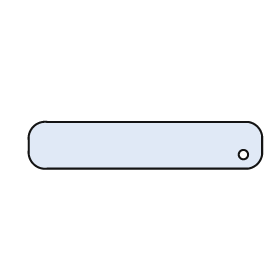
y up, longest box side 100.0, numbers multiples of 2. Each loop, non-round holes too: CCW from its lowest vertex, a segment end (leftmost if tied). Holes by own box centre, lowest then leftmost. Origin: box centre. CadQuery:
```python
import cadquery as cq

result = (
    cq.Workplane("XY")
    .moveTo(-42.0, -10.0)
    .lineTo(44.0, -10.0)
    .threePointArc((48.0, -8.0), (50.0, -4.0))
    .lineTo(50.0, 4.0)
    .threePointArc((48.0, 8.0), (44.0, 10.0))
    .lineTo(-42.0, 10.0)
    .threePointArc((-48.0, 8.0), (-50.0, 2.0))
    .lineTo(-50.0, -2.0)
    .threePointArc((-48.0, -8.0), (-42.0, -10.0))
    .close()
    .moveTo(42.0, -4.0)
    .circle(2.0)
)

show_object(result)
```